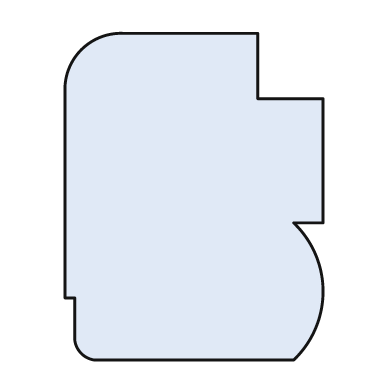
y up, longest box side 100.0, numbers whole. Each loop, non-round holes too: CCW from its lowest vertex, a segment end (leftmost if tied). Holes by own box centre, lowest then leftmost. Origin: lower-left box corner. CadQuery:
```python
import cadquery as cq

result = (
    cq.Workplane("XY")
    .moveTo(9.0, 0.0)
    .lineTo(70.0, 0.0)
    .threePointArc((79.0, 21.0), (70.0, 42.0))
    .lineTo(79.0, 42.0)
    .lineTo(79.0, 80.0)
    .lineTo(59.0, 80.0)
    .lineTo(59.0, 100.0)
    .lineTo(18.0, 100.0)
    .threePointArc((5.0, 95.0), (0.0, 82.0))
    .lineTo(0.0, 19.0)
    .lineTo(3.0, 19.0)
    .lineTo(3.0, 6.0)
    .threePointArc((5.0, 2.0), (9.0, 0.0))
    .close()
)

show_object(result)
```